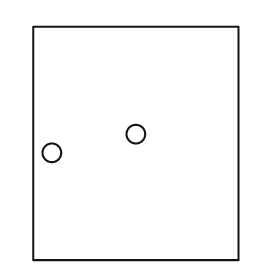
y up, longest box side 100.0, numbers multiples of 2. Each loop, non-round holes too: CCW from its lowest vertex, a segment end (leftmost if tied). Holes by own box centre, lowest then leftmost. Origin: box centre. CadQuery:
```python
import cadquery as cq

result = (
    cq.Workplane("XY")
    .moveTo(-44.0, -50.0)
    .lineTo(44.0, -50.0)
    .lineTo(44.0, 50.0)
    .lineTo(-44.0, 50.0)
    .close()
    .moveTo(-36.0, -4.0)
    .circle(4.0)
    .moveTo(0.0, 4.0)
    .circle(4.0)
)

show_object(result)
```